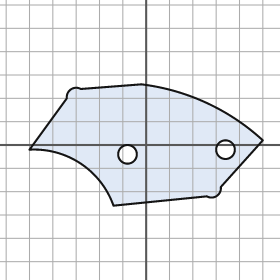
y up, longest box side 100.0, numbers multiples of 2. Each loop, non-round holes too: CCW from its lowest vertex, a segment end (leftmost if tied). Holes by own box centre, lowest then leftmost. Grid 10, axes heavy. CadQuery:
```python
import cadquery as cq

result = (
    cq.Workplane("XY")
    .moveTo(-14.0, -26.0)
    .lineTo(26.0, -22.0)
    .threePointArc((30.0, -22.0), (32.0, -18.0))
    .lineTo(50.0, 2.0)
    .threePointArc((26.0, 18.0), (-2.0, 26.0))
    .lineTo(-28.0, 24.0)
    .threePointArc((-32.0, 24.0), (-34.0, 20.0))
    .lineTo(-50.0, -2.0)
    .threePointArc((-28.0, -8.0), (-14.0, -26.0))
    .close()
    .moveTo(-8.0, -4.0)
    .circle(4.0)
    .moveTo(34.0, -2.0)
    .circle(4.0)
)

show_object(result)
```